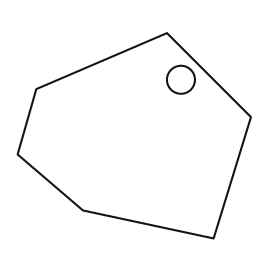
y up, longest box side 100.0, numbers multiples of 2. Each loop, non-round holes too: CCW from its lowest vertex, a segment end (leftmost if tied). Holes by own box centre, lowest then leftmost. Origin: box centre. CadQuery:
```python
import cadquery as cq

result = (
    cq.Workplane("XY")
    .moveTo(34.0, -44.0)
    .lineTo(50.0, 8.0)
    .lineTo(14.0, 44.0)
    .lineTo(-42.0, 20.0)
    .lineTo(-50.0, -8.0)
    .lineTo(-22.0, -32.0)
    .close()
    .moveTo(20.0, 24.0)
    .circle(6.0)
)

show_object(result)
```